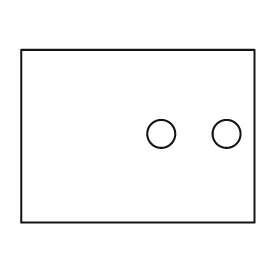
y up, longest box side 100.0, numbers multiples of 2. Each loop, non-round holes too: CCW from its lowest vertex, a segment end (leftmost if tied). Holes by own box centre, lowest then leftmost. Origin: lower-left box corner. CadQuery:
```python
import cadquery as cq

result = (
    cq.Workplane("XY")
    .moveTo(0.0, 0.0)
    .lineTo(100.0, 0.0)
    .lineTo(100.0, 74.0)
    .lineTo(0.0, 74.0)
    .close()
    .moveTo(60.0, 38.0)
    .circle(6.0)
    .moveTo(88.0, 38.0)
    .circle(6.0)
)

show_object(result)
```